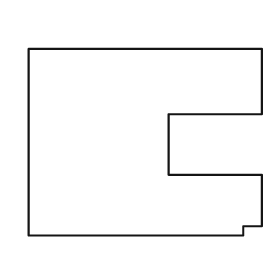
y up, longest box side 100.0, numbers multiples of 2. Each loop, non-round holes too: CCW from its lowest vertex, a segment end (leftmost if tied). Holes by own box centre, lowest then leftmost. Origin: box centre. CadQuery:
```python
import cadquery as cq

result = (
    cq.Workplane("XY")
    .moveTo(-50.0, -40.0)
    .lineTo(42.0, -40.0)
    .lineTo(42.0, -36.0)
    .lineTo(50.0, -36.0)
    .lineTo(50.0, -14.0)
    .lineTo(10.0, -14.0)
    .lineTo(10.0, 12.0)
    .lineTo(50.0, 12.0)
    .lineTo(50.0, 40.0)
    .lineTo(-50.0, 40.0)
    .close()
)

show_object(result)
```